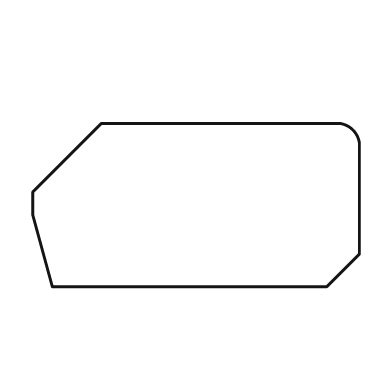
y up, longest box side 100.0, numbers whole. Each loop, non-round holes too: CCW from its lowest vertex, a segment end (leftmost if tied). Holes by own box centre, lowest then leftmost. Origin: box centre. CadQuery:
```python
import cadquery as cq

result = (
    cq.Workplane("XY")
    .moveTo(-44.0, -25.0)
    .lineTo(40.0, -25.0)
    .lineTo(50.0, -15.0)
    .lineTo(50.0, 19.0)
    .threePointArc((48.0, 23.0), (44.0, 25.0))
    .lineTo(-29.0, 25.0)
    .lineTo(-50.0, 4.0)
    .lineTo(-50.0, -3.0)
    .close()
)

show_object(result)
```